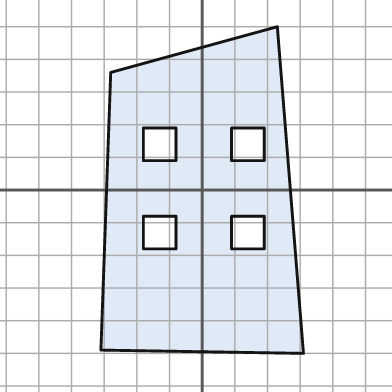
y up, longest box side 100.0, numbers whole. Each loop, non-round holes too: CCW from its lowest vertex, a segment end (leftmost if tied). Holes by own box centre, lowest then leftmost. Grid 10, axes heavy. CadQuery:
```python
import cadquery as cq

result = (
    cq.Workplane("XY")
    .moveTo(31.0, -50.0)
    .lineTo(23.0, 50.0)
    .lineTo(-28.0, 36.0)
    .lineTo(-31.0, -49.0)
    .close()
    .moveTo(-18.0, -18.0)
    .lineTo(-8.0, -18.0)
    .lineTo(-8.0, -8.0)
    .lineTo(-18.0, -8.0)
    .close()
    .moveTo(9.0, -18.0)
    .lineTo(19.0, -18.0)
    .lineTo(19.0, -8.0)
    .lineTo(9.0, -8.0)
    .close()
    .moveTo(-18.0, 9.0)
    .lineTo(-8.0, 9.0)
    .lineTo(-8.0, 19.0)
    .lineTo(-18.0, 19.0)
    .close()
    .moveTo(9.0, 9.0)
    .lineTo(19.0, 9.0)
    .lineTo(19.0, 19.0)
    .lineTo(9.0, 19.0)
    .close()
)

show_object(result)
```